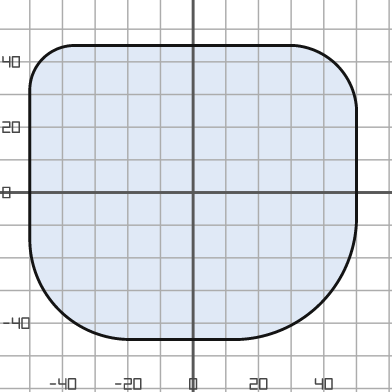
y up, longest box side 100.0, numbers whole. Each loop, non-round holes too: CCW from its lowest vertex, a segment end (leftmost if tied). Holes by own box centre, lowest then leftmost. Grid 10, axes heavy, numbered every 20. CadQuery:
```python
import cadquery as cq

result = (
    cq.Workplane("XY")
    .moveTo(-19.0, -45.0)
    .lineTo(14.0, -45.0)
    .threePointArc((39.0, -34.0), (50.0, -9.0))
    .lineTo(50.0, 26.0)
    .threePointArc((44.0, 39.0), (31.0, 45.0))
    .lineTo(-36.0, 45.0)
    .threePointArc((-46.0, 41.0), (-50.0, 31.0))
    .lineTo(-50.0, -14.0)
    .threePointArc((-41.0, -36.0), (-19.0, -45.0))
    .close()
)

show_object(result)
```